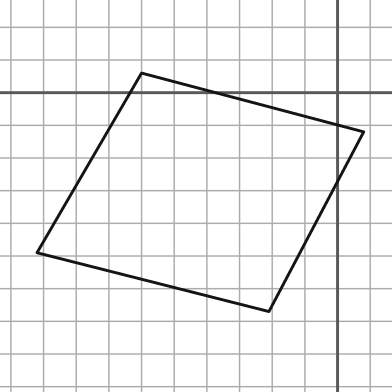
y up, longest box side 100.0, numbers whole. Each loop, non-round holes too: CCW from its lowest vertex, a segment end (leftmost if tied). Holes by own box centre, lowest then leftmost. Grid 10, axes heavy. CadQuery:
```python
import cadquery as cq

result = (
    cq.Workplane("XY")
    .moveTo(-21.0, -67.0)
    .lineTo(8.0, -12.0)
    .lineTo(-60.0, 6.0)
    .lineTo(-92.0, -49.0)
    .close()
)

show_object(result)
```